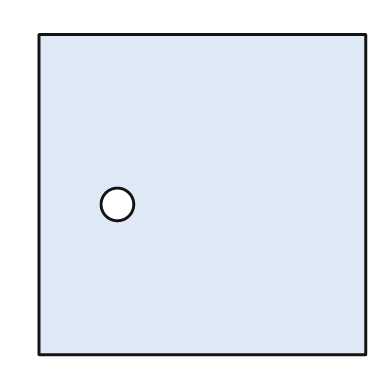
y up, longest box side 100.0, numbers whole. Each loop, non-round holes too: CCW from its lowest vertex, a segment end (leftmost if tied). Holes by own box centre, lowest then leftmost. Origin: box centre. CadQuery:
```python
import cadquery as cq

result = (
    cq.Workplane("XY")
    .moveTo(-50.0, -49.0)
    .lineTo(50.0, -49.0)
    .lineTo(50.0, 49.0)
    .lineTo(-50.0, 49.0)
    .close()
    .moveTo(-26.0, -3.0)
    .circle(5.0)
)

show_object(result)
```